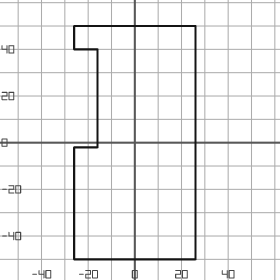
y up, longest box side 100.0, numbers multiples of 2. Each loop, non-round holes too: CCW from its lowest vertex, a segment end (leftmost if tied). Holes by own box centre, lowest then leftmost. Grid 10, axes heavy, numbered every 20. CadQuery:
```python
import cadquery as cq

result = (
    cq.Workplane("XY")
    .moveTo(-26.0, -50.0)
    .lineTo(26.0, -50.0)
    .lineTo(26.0, 50.0)
    .lineTo(-26.0, 50.0)
    .lineTo(-26.0, 40.0)
    .lineTo(-16.0, 40.0)
    .lineTo(-16.0, -2.0)
    .lineTo(-26.0, -2.0)
    .close()
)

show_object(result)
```